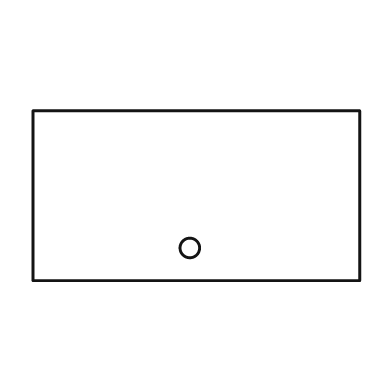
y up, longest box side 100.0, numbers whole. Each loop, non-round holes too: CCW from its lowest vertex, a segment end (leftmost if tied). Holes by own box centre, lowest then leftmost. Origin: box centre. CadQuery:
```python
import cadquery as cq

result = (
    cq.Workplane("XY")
    .moveTo(-50.0, -26.0)
    .lineTo(50.0, -26.0)
    .lineTo(50.0, 26.0)
    .lineTo(-50.0, 26.0)
    .close()
    .moveTo(-2.0, -16.0)
    .circle(3.0)
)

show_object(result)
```